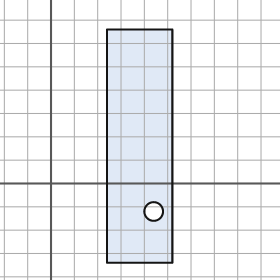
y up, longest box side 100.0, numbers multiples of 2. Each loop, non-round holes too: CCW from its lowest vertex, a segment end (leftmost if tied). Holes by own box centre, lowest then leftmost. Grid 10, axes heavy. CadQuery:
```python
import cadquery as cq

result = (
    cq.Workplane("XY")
    .moveTo(24.0, -34.0)
    .lineTo(52.0, -34.0)
    .lineTo(52.0, 66.0)
    .lineTo(24.0, 66.0)
    .close()
    .moveTo(44.0, -12.0)
    .circle(4.0)
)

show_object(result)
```